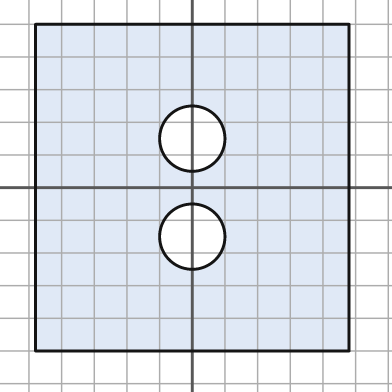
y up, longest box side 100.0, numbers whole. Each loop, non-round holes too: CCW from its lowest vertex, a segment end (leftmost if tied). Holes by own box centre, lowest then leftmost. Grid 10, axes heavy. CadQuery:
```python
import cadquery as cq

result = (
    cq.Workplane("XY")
    .moveTo(-48.0, -50.0)
    .lineTo(48.0, -50.0)
    .lineTo(48.0, 50.0)
    .lineTo(-48.0, 50.0)
    .close()
    .moveTo(0.0, -15.0)
    .circle(10.0)
    .moveTo(0.0, 15.0)
    .circle(10.0)
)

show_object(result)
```